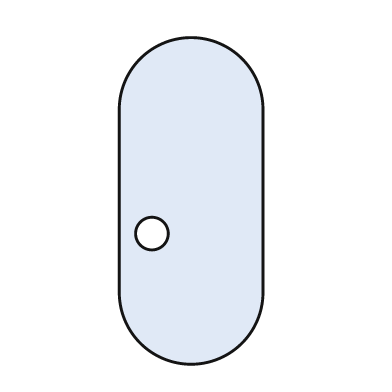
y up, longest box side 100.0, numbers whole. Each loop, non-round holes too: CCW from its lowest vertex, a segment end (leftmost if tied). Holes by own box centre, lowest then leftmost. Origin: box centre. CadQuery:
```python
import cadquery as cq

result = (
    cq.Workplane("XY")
    .moveTo(-22.0, -28.0)
    .threePointArc((0.0, -50.0), (22.0, -28.0))
    .lineTo(22.0, 28.0)
    .threePointArc((0.0, 50.0), (-22.0, 28.0))
    .close()
    .moveTo(-12.0, -10.0)
    .circle(5.0)
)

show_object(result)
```